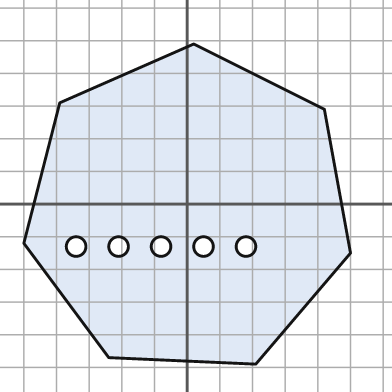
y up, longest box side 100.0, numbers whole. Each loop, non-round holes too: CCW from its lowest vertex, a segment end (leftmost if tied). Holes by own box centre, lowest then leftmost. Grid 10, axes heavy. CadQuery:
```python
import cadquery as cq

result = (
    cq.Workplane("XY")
    .moveTo(21.0, -49.0)
    .lineTo(50.0, -15.0)
    .lineTo(42.0, 29.0)
    .lineTo(2.0, 49.0)
    .lineTo(-39.0, 31.0)
    .lineTo(-50.0, -12.0)
    .lineTo(-24.0, -47.0)
    .close()
    .moveTo(-34.0, -13.0)
    .circle(3.0)
    .moveTo(-21.0, -13.0)
    .circle(3.0)
    .moveTo(-8.0, -13.0)
    .circle(3.0)
    .moveTo(5.0, -13.0)
    .circle(3.0)
    .moveTo(18.0, -13.0)
    .circle(3.0)
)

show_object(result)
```